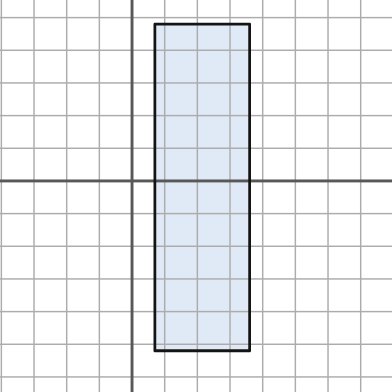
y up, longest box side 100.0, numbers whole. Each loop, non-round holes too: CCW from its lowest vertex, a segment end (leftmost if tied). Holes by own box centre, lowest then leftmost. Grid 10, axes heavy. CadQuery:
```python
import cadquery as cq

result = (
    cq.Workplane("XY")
    .moveTo(7.0, -52.0)
    .lineTo(36.0, -52.0)
    .lineTo(36.0, 48.0)
    .lineTo(7.0, 48.0)
    .close()
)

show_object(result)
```